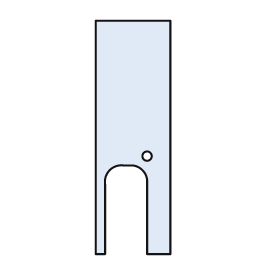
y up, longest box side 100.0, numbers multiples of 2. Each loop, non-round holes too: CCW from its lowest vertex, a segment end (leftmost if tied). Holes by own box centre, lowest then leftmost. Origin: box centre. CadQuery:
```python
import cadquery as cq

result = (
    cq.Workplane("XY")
    .moveTo(-16.0, -50.0)
    .lineTo(-12.0, -50.0)
    .lineTo(-12.0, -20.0)
    .threePointArc((-10.0, -14.0), (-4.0, -12.0))
    .lineTo(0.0, -12.0)
    .threePointArc((4.0, -14.0), (6.0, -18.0))
    .lineTo(6.0, -50.0)
    .lineTo(16.0, -50.0)
    .lineTo(16.0, 50.0)
    .lineTo(-16.0, 50.0)
    .close()
    .moveTo(6.0, -8.0)
    .circle(2.0)
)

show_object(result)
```